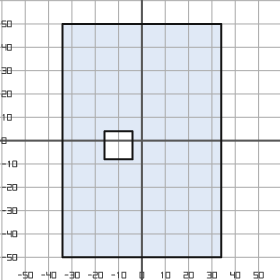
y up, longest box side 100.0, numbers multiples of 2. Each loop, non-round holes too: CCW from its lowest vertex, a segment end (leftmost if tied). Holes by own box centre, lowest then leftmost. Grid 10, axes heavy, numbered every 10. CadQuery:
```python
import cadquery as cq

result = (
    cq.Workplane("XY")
    .moveTo(-34.0, -50.0)
    .lineTo(34.0, -50.0)
    .lineTo(34.0, 50.0)
    .lineTo(-34.0, 50.0)
    .close()
    .moveTo(-16.0, -8.0)
    .lineTo(-4.0, -8.0)
    .lineTo(-4.0, 4.0)
    .lineTo(-16.0, 4.0)
    .close()
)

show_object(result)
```